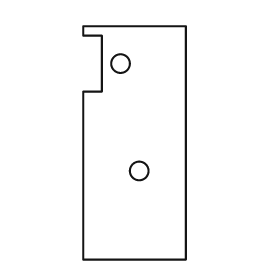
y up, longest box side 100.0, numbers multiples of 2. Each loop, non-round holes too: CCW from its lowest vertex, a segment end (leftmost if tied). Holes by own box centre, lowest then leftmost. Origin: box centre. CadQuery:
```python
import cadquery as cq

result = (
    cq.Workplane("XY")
    .moveTo(-22.0, -50.0)
    .lineTo(22.0, -50.0)
    .lineTo(22.0, 50.0)
    .lineTo(-22.0, 50.0)
    .lineTo(-22.0, 46.0)
    .lineTo(-14.0, 46.0)
    .lineTo(-14.0, 22.0)
    .lineTo(-22.0, 22.0)
    .close()
    .moveTo(2.0, -12.0)
    .circle(4.0)
    .moveTo(-6.0, 34.0)
    .circle(4.0)
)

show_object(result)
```